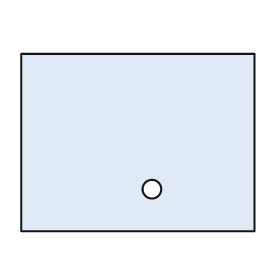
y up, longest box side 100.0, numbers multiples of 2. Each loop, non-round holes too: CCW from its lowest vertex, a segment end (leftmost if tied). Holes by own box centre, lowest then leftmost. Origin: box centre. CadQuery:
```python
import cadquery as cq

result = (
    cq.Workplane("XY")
    .moveTo(-50.0, -38.0)
    .lineTo(50.0, -38.0)
    .lineTo(50.0, 38.0)
    .lineTo(-50.0, 38.0)
    .close()
    .moveTo(6.0, -20.0)
    .circle(4.0)
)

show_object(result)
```